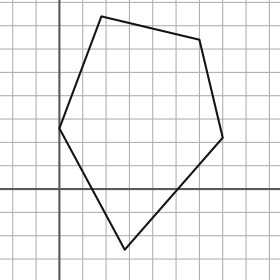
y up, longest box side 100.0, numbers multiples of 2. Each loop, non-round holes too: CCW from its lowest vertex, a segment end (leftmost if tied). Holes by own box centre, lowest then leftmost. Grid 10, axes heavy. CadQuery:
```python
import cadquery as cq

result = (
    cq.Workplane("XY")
    .moveTo(28.0, -26.0)
    .lineTo(70.0, 22.0)
    .lineTo(60.0, 64.0)
    .lineTo(18.0, 74.0)
    .lineTo(0.0, 26.0)
    .close()
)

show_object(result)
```